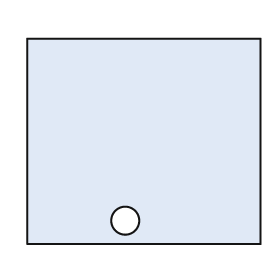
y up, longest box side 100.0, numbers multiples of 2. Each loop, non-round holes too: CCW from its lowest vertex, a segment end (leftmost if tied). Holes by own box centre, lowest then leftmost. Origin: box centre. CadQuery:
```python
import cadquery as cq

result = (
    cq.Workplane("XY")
    .moveTo(-50.0, -44.0)
    .lineTo(50.0, -44.0)
    .lineTo(50.0, 44.0)
    .lineTo(-50.0, 44.0)
    .close()
    .moveTo(-8.0, -34.0)
    .circle(6.0)
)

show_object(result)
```